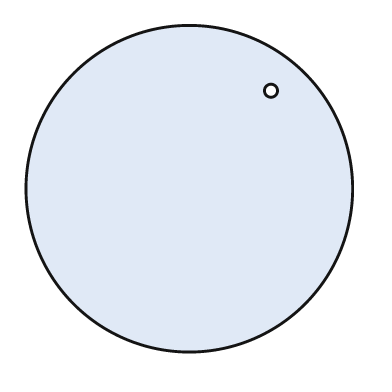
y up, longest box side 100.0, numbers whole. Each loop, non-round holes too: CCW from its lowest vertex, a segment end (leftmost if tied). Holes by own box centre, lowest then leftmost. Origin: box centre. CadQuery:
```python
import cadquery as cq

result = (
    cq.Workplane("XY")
    .moveTo(0.0, 0.0)
    .circle(50.0)
    .moveTo(25.0, 30.0)
    .circle(2.0)
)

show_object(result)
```